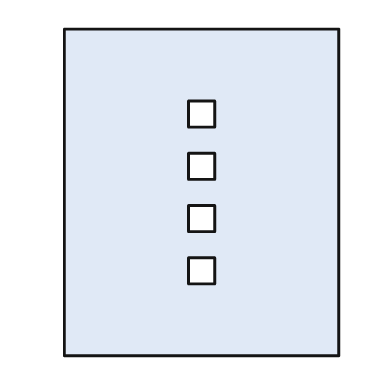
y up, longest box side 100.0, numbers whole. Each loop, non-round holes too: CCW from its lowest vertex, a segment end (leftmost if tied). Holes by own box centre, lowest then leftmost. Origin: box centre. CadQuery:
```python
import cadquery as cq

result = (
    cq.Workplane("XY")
    .moveTo(-42.0, -50.0)
    .lineTo(42.0, -50.0)
    .lineTo(42.0, 50.0)
    .lineTo(-42.0, 50.0)
    .close()
    .moveTo(-4.0, -28.0)
    .lineTo(4.0, -28.0)
    .lineTo(4.0, -20.0)
    .lineTo(-4.0, -20.0)
    .close()
    .moveTo(-4.0, -12.0)
    .lineTo(4.0, -12.0)
    .lineTo(4.0, -4.0)
    .lineTo(-4.0, -4.0)
    .close()
    .moveTo(-4.0, 4.0)
    .lineTo(4.0, 4.0)
    .lineTo(4.0, 12.0)
    .lineTo(-4.0, 12.0)
    .close()
    .moveTo(-4.0, 20.0)
    .lineTo(4.0, 20.0)
    .lineTo(4.0, 28.0)
    .lineTo(-4.0, 28.0)
    .close()
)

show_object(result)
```